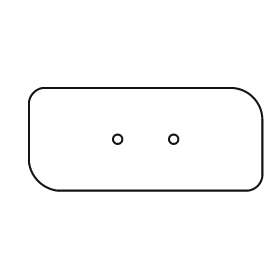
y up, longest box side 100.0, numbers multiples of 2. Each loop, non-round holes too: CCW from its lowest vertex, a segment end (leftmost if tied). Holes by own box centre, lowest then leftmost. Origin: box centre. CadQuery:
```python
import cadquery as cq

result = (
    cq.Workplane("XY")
    .moveTo(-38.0, -22.0)
    .lineTo(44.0, -22.0)
    .threePointArc((48.0, -20.0), (50.0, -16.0))
    .lineTo(50.0, 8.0)
    .threePointArc((46.0, 18.0), (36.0, 22.0))
    .lineTo(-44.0, 22.0)
    .threePointArc((-48.0, 20.0), (-50.0, 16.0))
    .lineTo(-50.0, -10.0)
    .threePointArc((-46.0, -18.0), (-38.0, -22.0))
    .close()
    .moveTo(-12.0, 0.0)
    .circle(2.0)
    .moveTo(12.0, 0.0)
    .circle(2.0)
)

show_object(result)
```